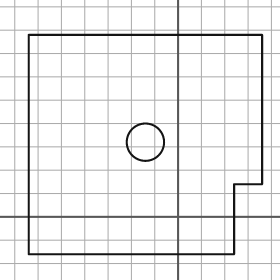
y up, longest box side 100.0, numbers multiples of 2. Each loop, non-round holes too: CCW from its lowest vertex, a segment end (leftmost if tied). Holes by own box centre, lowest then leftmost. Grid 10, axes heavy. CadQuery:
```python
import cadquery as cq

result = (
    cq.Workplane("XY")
    .moveTo(-64.0, -16.0)
    .lineTo(24.0, -16.0)
    .lineTo(24.0, 14.0)
    .lineTo(36.0, 14.0)
    .lineTo(36.0, 78.0)
    .lineTo(-64.0, 78.0)
    .close()
    .moveTo(-14.0, 32.0)
    .circle(8.0)
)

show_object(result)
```